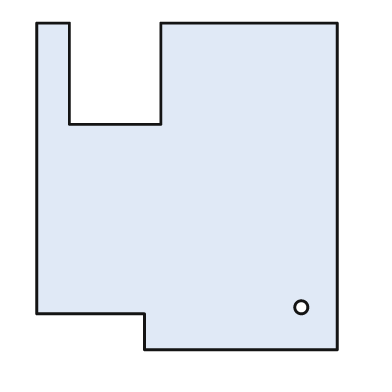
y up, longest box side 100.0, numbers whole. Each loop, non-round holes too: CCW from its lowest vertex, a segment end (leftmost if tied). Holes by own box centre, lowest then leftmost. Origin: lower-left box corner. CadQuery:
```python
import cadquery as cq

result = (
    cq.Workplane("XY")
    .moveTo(33.0, 0.0)
    .lineTo(92.0, 0.0)
    .lineTo(92.0, 100.0)
    .lineTo(38.0, 100.0)
    .lineTo(38.0, 69.0)
    .lineTo(10.0, 69.0)
    .lineTo(10.0, 100.0)
    .lineTo(0.0, 100.0)
    .lineTo(0.0, 11.0)
    .lineTo(33.0, 11.0)
    .close()
    .moveTo(81.0, 13.0)
    .circle(2.0)
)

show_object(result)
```